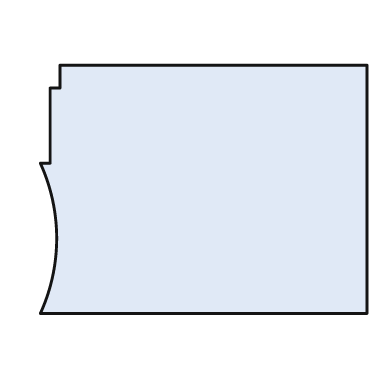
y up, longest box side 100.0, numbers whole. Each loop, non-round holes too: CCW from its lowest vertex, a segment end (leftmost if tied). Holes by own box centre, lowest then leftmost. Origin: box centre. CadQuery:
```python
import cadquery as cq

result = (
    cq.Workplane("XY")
    .moveTo(-50.0, -38.0)
    .lineTo(50.0, -38.0)
    .lineTo(50.0, 38.0)
    .lineTo(-44.0, 38.0)
    .lineTo(-44.0, 31.0)
    .lineTo(-47.0, 31.0)
    .lineTo(-47.0, 8.0)
    .lineTo(-50.0, 8.0)
    .threePointArc((-45.0, -15.0), (-50.0, -38.0))
    .close()
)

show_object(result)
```